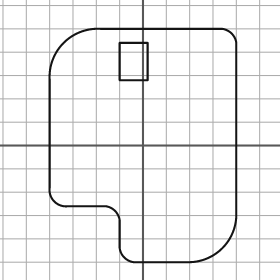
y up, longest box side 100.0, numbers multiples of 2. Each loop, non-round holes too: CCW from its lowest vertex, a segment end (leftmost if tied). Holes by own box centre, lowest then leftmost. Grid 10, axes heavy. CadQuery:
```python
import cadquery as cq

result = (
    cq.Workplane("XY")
    .moveTo(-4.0, -50.0)
    .lineTo(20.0, -50.0)
    .threePointArc((34.0, -44.0), (40.0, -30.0))
    .lineTo(40.0, 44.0)
    .threePointArc((38.0, 48.0), (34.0, 50.0))
    .lineTo(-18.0, 50.0)
    .threePointArc((-34.0, 44.0), (-40.0, 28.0))
    .lineTo(-40.0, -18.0)
    .threePointArc((-38.0, -24.0), (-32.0, -26.0))
    .lineTo(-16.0, -26.0)
    .threePointArc((-12.0, -28.0), (-10.0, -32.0))
    .lineTo(-10.0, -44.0)
    .threePointArc((-8.0, -48.0), (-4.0, -50.0))
    .close()
    .moveTo(-10.0, 28.0)
    .lineTo(2.0, 28.0)
    .lineTo(2.0, 44.0)
    .lineTo(-10.0, 44.0)
    .close()
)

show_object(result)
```